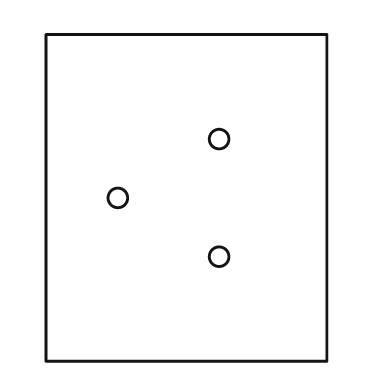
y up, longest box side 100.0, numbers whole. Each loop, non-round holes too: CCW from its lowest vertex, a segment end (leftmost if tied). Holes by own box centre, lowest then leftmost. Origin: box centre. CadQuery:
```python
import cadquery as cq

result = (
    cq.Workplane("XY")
    .moveTo(-43.0, -50.0)
    .lineTo(43.0, -50.0)
    .lineTo(43.0, 50.0)
    .lineTo(-43.0, 50.0)
    .close()
    .moveTo(10.0, -18.0)
    .circle(3.0)
    .moveTo(-21.0, 0.0)
    .circle(3.0)
    .moveTo(10.0, 18.0)
    .circle(3.0)
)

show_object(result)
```